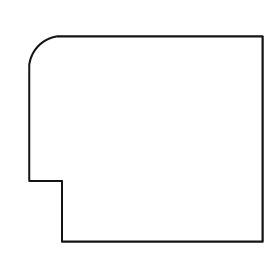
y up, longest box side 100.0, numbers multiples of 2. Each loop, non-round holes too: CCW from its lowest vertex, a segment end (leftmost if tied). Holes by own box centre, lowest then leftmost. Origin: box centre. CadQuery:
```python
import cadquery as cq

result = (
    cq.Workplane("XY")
    .moveTo(-36.0, -44.0)
    .lineTo(50.0, -44.0)
    .lineTo(50.0, 44.0)
    .lineTo(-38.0, 44.0)
    .threePointArc((-46.0, 40.0), (-50.0, 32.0))
    .lineTo(-50.0, -18.0)
    .lineTo(-36.0, -18.0)
    .close()
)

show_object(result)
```